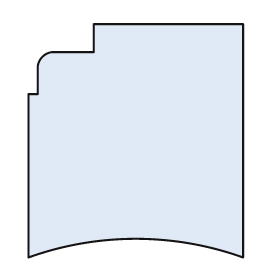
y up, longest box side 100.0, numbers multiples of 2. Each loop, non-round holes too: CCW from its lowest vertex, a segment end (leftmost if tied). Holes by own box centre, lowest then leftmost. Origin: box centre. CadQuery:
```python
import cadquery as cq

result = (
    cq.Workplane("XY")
    .moveTo(-46.0, -50.0)
    .threePointArc((0.0, -42.0), (46.0, -50.0))
    .lineTo(46.0, 50.0)
    .lineTo(-18.0, 50.0)
    .lineTo(-18.0, 38.0)
    .lineTo(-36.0, 38.0)
    .threePointArc((-40.0, 36.0), (-42.0, 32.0))
    .lineTo(-42.0, 20.0)
    .lineTo(-46.0, 20.0)
    .close()
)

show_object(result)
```